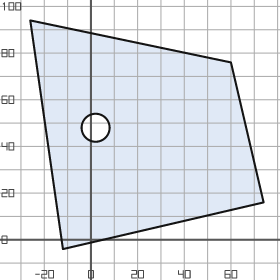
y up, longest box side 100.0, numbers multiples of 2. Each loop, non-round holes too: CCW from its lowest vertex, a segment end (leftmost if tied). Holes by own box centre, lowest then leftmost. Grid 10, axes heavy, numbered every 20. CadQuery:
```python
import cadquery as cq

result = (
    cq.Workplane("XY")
    .moveTo(-12.0, -4.0)
    .lineTo(74.0, 16.0)
    .lineTo(60.0, 76.0)
    .lineTo(-26.0, 94.0)
    .close()
    .moveTo(2.0, 48.0)
    .circle(6.0)
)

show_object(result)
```